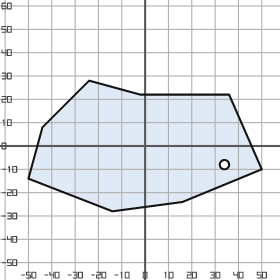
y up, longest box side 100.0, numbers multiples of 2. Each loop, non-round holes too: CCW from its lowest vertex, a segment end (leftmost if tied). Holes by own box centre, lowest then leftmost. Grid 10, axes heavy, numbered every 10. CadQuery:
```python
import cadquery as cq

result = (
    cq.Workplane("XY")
    .moveTo(-14.0, -28.0)
    .lineTo(16.0, -24.0)
    .lineTo(50.0, -10.0)
    .lineTo(36.0, 22.0)
    .lineTo(-2.0, 22.0)
    .lineTo(-24.0, 28.0)
    .lineTo(-44.0, 8.0)
    .lineTo(-50.0, -14.0)
    .close()
    .moveTo(34.0, -8.0)
    .circle(2.0)
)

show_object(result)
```